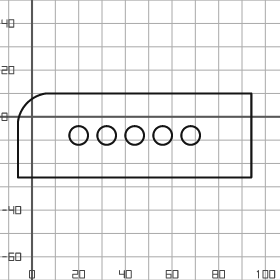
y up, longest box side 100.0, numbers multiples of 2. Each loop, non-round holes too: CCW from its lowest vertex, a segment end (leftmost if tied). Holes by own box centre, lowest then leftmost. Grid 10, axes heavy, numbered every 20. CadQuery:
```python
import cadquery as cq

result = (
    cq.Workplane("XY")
    .moveTo(-6.0, -26.0)
    .lineTo(94.0, -26.0)
    .lineTo(94.0, 10.0)
    .lineTo(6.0, 10.0)
    .threePointArc((-2.0, 6.0), (-6.0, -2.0))
    .close()
    .moveTo(20.0, -8.0)
    .circle(4.0)
    .moveTo(32.0, -8.0)
    .circle(4.0)
    .moveTo(44.0, -8.0)
    .circle(4.0)
    .moveTo(56.0, -8.0)
    .circle(4.0)
    .moveTo(68.0, -8.0)
    .circle(4.0)
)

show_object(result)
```